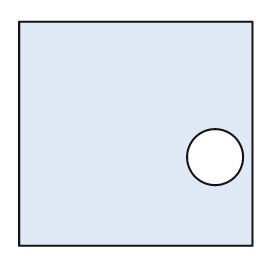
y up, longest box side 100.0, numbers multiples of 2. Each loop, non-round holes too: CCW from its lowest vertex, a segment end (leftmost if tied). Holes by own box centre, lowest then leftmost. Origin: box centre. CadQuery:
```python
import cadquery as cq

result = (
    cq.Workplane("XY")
    .moveTo(-50.0, -48.0)
    .lineTo(50.0, -48.0)
    .lineTo(50.0, 48.0)
    .lineTo(-50.0, 48.0)
    .close()
    .moveTo(34.0, -10.0)
    .circle(12.0)
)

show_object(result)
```